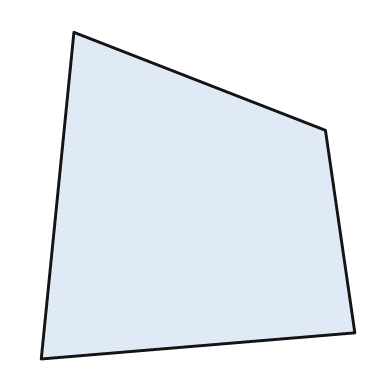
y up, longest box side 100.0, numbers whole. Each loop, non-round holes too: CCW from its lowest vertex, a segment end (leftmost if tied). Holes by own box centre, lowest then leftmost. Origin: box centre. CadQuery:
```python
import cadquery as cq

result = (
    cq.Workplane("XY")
    .moveTo(-48.0, -50.0)
    .lineTo(48.0, -42.0)
    .lineTo(39.0, 20.0)
    .lineTo(-38.0, 50.0)
    .close()
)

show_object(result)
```